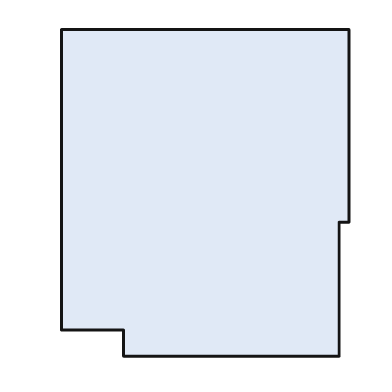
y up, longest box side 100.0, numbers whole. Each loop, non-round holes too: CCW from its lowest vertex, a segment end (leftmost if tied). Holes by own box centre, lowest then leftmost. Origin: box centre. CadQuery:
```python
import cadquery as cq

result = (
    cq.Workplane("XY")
    .moveTo(-25.0, -50.0)
    .lineTo(41.0, -50.0)
    .lineTo(41.0, -9.0)
    .lineTo(44.0, -9.0)
    .lineTo(44.0, 50.0)
    .lineTo(-44.0, 50.0)
    .lineTo(-44.0, -42.0)
    .lineTo(-25.0, -42.0)
    .close()
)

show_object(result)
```